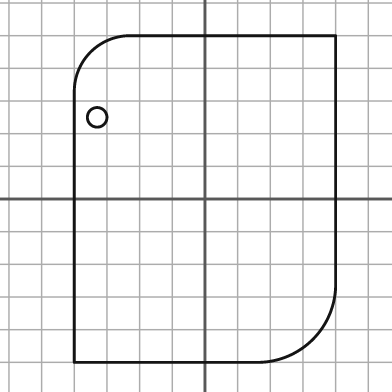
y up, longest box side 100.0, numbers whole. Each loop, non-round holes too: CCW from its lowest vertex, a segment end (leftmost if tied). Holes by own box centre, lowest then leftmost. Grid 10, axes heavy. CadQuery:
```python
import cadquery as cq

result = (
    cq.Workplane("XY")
    .moveTo(-40.0, -50.0)
    .lineTo(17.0, -50.0)
    .threePointArc((33.0, -43.0), (40.0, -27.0))
    .lineTo(40.0, 50.0)
    .lineTo(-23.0, 50.0)
    .threePointArc((-35.0, 45.0), (-40.0, 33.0))
    .close()
    .moveTo(-33.0, 25.0)
    .circle(3.0)
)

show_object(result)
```